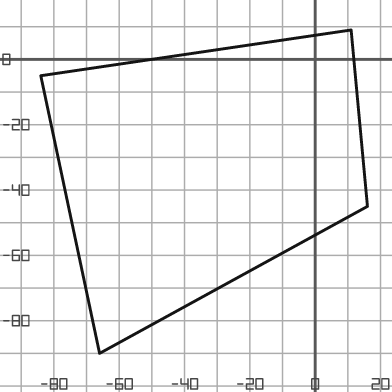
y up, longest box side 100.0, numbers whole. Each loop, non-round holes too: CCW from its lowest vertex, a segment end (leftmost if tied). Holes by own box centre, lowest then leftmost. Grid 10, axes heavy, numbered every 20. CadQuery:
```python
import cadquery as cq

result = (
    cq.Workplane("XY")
    .moveTo(-66.0, -90.0)
    .lineTo(16.0, -45.0)
    .lineTo(11.0, 9.0)
    .lineTo(-84.0, -5.0)
    .close()
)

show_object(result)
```